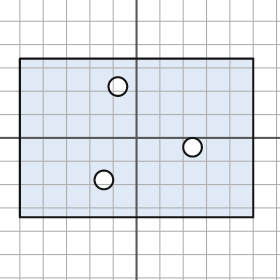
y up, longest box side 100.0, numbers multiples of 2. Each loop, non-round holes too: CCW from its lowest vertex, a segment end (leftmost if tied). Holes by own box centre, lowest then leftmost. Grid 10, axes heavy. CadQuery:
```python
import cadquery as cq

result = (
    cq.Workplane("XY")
    .moveTo(-50.0, -34.0)
    .lineTo(50.0, -34.0)
    .lineTo(50.0, 34.0)
    .lineTo(-50.0, 34.0)
    .close()
    .moveTo(-14.0, -18.0)
    .circle(4.0)
    .moveTo(24.0, -4.0)
    .circle(4.0)
    .moveTo(-8.0, 22.0)
    .circle(4.0)
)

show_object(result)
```